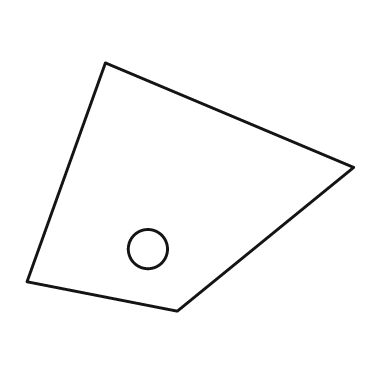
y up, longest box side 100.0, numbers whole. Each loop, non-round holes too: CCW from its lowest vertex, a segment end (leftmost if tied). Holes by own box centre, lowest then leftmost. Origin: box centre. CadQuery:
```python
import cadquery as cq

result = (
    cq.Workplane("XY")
    .moveTo(-4.0, -38.0)
    .lineTo(50.0, 6.0)
    .lineTo(-26.0, 38.0)
    .lineTo(-50.0, -29.0)
    .close()
    .moveTo(-13.0, -19.0)
    .circle(6.0)
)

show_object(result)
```